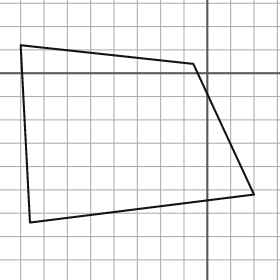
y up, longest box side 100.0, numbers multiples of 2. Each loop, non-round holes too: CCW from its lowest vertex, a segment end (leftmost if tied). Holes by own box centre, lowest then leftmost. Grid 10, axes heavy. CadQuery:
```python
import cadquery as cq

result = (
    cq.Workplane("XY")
    .moveTo(-76.0, -64.0)
    .lineTo(20.0, -52.0)
    .lineTo(-6.0, 4.0)
    .lineTo(-80.0, 12.0)
    .close()
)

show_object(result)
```